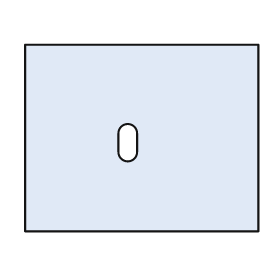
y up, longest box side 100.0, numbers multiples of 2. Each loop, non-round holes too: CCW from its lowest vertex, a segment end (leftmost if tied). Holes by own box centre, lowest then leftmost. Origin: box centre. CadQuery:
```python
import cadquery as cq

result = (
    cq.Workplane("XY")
    .moveTo(-50.0, -40.0)
    .lineTo(50.0, -40.0)
    .lineTo(50.0, 40.0)
    .lineTo(-50.0, 40.0)
    .close()
    .moveTo(-10.0, -6.0)
    .threePointArc((-6.0, -10.0), (-2.0, -6.0))
    .lineTo(-2.0, 2.0)
    .threePointArc((-6.0, 6.0), (-10.0, 2.0))
    .close()
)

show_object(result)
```